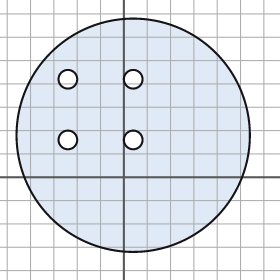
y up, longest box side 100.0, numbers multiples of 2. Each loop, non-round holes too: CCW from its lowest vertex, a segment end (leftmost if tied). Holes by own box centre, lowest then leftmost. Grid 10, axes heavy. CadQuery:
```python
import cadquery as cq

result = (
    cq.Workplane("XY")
    .moveTo(4.0, 18.0)
    .circle(50.0)
    .moveTo(-24.0, 16.0)
    .circle(4.0)
    .moveTo(4.0, 16.0)
    .circle(4.0)
    .moveTo(-24.0, 42.0)
    .circle(4.0)
    .moveTo(4.0, 42.0)
    .circle(4.0)
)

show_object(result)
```